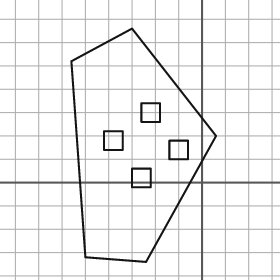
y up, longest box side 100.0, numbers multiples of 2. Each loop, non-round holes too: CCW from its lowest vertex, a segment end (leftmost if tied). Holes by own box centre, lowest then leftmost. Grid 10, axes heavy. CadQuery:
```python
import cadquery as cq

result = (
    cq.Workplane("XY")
    .moveTo(-24.0, -34.0)
    .lineTo(6.0, 20.0)
    .lineTo(-30.0, 66.0)
    .lineTo(-56.0, 52.0)
    .lineTo(-50.0, -32.0)
    .close()
    .moveTo(-30.0, -2.0)
    .lineTo(-22.0, -2.0)
    .lineTo(-22.0, 6.0)
    .lineTo(-30.0, 6.0)
    .close()
    .moveTo(-14.0, 10.0)
    .lineTo(-6.0, 10.0)
    .lineTo(-6.0, 18.0)
    .lineTo(-14.0, 18.0)
    .close()
    .moveTo(-42.0, 14.0)
    .lineTo(-34.0, 14.0)
    .lineTo(-34.0, 22.0)
    .lineTo(-42.0, 22.0)
    .close()
    .moveTo(-26.0, 26.0)
    .lineTo(-18.0, 26.0)
    .lineTo(-18.0, 34.0)
    .lineTo(-26.0, 34.0)
    .close()
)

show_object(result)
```